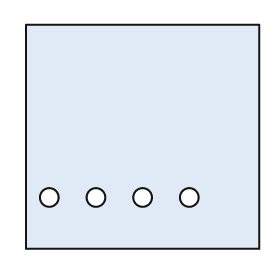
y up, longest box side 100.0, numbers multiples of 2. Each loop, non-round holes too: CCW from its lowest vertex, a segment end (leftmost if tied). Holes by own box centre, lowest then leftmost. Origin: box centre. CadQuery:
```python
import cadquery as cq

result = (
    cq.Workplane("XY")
    .moveTo(-50.0, -48.0)
    .lineTo(50.0, -48.0)
    .lineTo(50.0, 48.0)
    .lineTo(-50.0, 48.0)
    .close()
    .moveTo(-40.0, -26.0)
    .circle(4.0)
    .moveTo(-20.0, -26.0)
    .circle(4.0)
    .moveTo(0.0, -26.0)
    .circle(4.0)
    .moveTo(20.0, -26.0)
    .circle(4.0)
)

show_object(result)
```